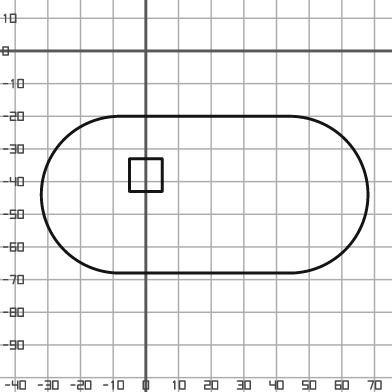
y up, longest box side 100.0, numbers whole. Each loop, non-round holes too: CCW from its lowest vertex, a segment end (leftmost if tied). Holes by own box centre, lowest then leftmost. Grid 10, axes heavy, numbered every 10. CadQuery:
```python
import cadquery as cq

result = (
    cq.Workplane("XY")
    .moveTo(-8.0, -68.0)
    .lineTo(44.0, -68.0)
    .threePointArc((68.0, -44.0), (44.0, -20.0))
    .lineTo(-8.0, -20.0)
    .threePointArc((-32.0, -44.0), (-8.0, -68.0))
    .close()
    .moveTo(-5.0, -43.0)
    .lineTo(5.0, -43.0)
    .lineTo(5.0, -33.0)
    .lineTo(-5.0, -33.0)
    .close()
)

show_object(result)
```